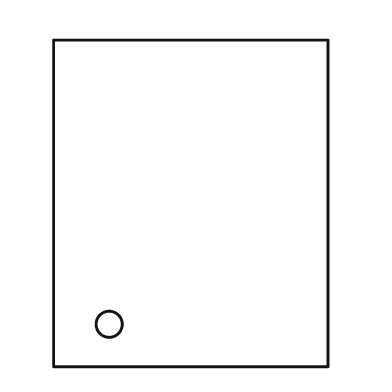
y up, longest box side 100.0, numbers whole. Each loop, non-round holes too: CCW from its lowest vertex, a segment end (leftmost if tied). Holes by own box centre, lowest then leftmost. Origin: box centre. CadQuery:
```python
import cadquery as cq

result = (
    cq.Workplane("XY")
    .moveTo(-42.0, -50.0)
    .lineTo(42.0, -50.0)
    .lineTo(42.0, 50.0)
    .lineTo(-42.0, 50.0)
    .close()
    .moveTo(-25.0, -37.0)
    .circle(4.0)
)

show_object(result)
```